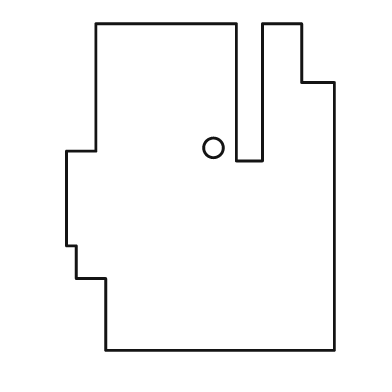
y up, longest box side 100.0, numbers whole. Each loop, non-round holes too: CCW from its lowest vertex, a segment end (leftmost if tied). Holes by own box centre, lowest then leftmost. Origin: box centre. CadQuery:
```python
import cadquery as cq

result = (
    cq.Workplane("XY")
    .moveTo(-29.0, -50.0)
    .lineTo(41.0, -50.0)
    .lineTo(41.0, 32.0)
    .lineTo(31.0, 32.0)
    .lineTo(31.0, 50.0)
    .lineTo(19.0, 50.0)
    .lineTo(19.0, 8.0)
    .lineTo(11.0, 8.0)
    .lineTo(11.0, 50.0)
    .lineTo(-32.0, 50.0)
    .lineTo(-32.0, 11.0)
    .lineTo(-41.0, 11.0)
    .lineTo(-41.0, -18.0)
    .lineTo(-38.0, -18.0)
    .lineTo(-38.0, -28.0)
    .lineTo(-29.0, -28.0)
    .close()
    .moveTo(4.0, 12.0)
    .circle(3.0)
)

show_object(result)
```